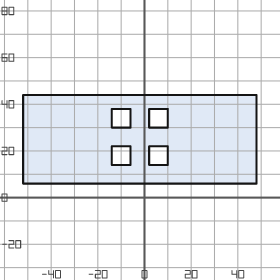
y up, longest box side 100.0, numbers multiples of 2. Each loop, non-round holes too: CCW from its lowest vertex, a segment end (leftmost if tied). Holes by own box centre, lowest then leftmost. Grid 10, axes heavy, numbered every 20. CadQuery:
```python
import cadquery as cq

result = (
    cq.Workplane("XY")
    .moveTo(-52.0, 6.0)
    .lineTo(48.0, 6.0)
    .lineTo(48.0, 44.0)
    .lineTo(-52.0, 44.0)
    .close()
    .moveTo(-14.0, 14.0)
    .lineTo(-6.0, 14.0)
    .lineTo(-6.0, 22.0)
    .lineTo(-14.0, 22.0)
    .close()
    .moveTo(2.0, 14.0)
    .lineTo(10.0, 14.0)
    .lineTo(10.0, 22.0)
    .lineTo(2.0, 22.0)
    .close()
    .moveTo(-14.0, 30.0)
    .lineTo(-6.0, 30.0)
    .lineTo(-6.0, 38.0)
    .lineTo(-14.0, 38.0)
    .close()
    .moveTo(2.0, 30.0)
    .lineTo(10.0, 30.0)
    .lineTo(10.0, 38.0)
    .lineTo(2.0, 38.0)
    .close()
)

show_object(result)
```